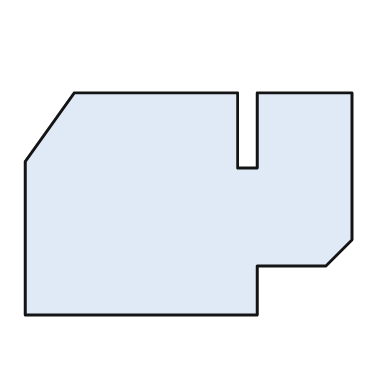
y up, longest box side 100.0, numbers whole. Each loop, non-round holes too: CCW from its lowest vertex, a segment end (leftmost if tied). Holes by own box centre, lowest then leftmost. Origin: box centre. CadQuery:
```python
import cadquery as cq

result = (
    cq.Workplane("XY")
    .moveTo(-50.0, -34.0)
    .lineTo(21.0, -34.0)
    .lineTo(21.0, -19.0)
    .lineTo(42.0, -19.0)
    .lineTo(50.0, -11.0)
    .lineTo(50.0, 34.0)
    .lineTo(21.0, 34.0)
    .lineTo(21.0, 11.0)
    .lineTo(15.0, 11.0)
    .lineTo(15.0, 34.0)
    .lineTo(-35.0, 34.0)
    .lineTo(-50.0, 13.0)
    .close()
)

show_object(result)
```